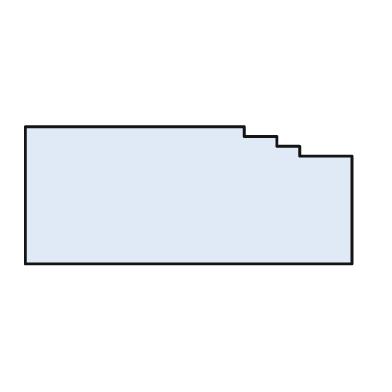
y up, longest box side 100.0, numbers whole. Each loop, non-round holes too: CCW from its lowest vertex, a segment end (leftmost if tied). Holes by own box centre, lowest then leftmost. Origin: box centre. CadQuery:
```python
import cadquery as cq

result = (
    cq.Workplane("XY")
    .moveTo(-50.0, -21.0)
    .lineTo(50.0, -21.0)
    .lineTo(50.0, 12.0)
    .lineTo(34.0, 12.0)
    .lineTo(34.0, 15.0)
    .lineTo(27.0, 15.0)
    .lineTo(27.0, 18.0)
    .lineTo(17.0, 18.0)
    .lineTo(17.0, 21.0)
    .lineTo(-50.0, 21.0)
    .close()
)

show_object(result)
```